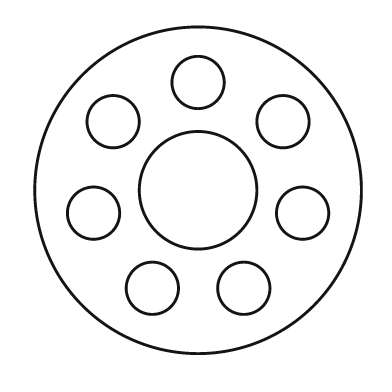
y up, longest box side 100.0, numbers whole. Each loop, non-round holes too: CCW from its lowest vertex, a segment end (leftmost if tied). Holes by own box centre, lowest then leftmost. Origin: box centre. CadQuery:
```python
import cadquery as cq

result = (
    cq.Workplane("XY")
    .moveTo(0.0, 0.0)
    .circle(50.0)
    .moveTo(-14.0, -30.0)
    .circle(8.0)
    .moveTo(14.0, -30.0)
    .circle(8.0)
    .moveTo(-32.0, -7.0)
    .circle(8.0)
    .moveTo(32.0, -7.0)
    .circle(8.0)
    .moveTo(0.0, 0.0)
    .circle(18.0)
    .moveTo(-26.0, 21.0)
    .circle(8.0)
    .moveTo(26.0, 21.0)
    .circle(8.0)
    .moveTo(0.0, 33.0)
    .circle(8.0)
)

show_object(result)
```